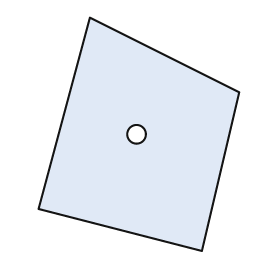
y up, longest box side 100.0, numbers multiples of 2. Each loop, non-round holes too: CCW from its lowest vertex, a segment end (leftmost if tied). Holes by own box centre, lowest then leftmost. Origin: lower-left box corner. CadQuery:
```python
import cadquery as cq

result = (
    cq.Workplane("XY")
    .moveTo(70.0, 0.0)
    .lineTo(86.0, 68.0)
    .lineTo(22.0, 100.0)
    .lineTo(0.0, 18.0)
    .close()
    .moveTo(42.0, 50.0)
    .circle(4.0)
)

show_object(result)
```